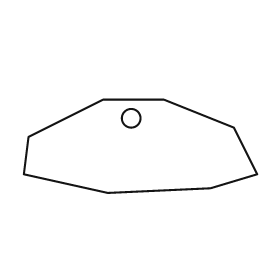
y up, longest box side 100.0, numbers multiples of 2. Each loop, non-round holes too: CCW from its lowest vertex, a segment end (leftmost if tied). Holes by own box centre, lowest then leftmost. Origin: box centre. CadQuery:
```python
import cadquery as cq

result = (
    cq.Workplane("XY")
    .moveTo(-14.0, -20.0)
    .lineTo(30.0, -18.0)
    .lineTo(50.0, -12.0)
    .lineTo(40.0, 8.0)
    .lineTo(10.0, 20.0)
    .lineTo(-16.0, 20.0)
    .lineTo(-48.0, 4.0)
    .lineTo(-50.0, -12.0)
    .close()
    .moveTo(-4.0, 12.0)
    .circle(4.0)
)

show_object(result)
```